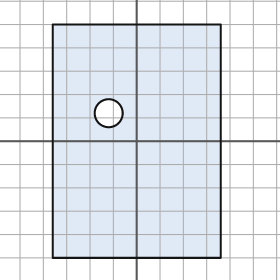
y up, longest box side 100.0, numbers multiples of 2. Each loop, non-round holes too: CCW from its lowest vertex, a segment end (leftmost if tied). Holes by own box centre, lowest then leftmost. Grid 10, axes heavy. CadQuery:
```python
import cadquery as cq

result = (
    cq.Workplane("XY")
    .moveTo(-36.0, -50.0)
    .lineTo(36.0, -50.0)
    .lineTo(36.0, 50.0)
    .lineTo(-36.0, 50.0)
    .close()
    .moveTo(-12.0, 12.0)
    .circle(6.0)
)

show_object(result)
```